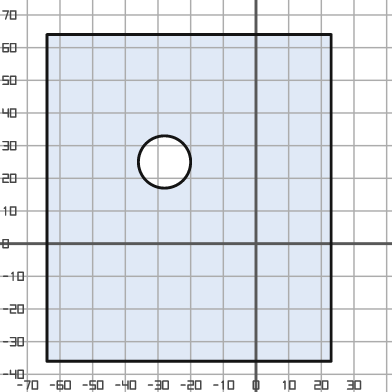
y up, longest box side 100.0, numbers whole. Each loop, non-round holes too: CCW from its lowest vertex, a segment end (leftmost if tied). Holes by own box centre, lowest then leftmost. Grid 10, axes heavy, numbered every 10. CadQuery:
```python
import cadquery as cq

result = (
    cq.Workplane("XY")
    .moveTo(-64.0, -36.0)
    .lineTo(23.0, -36.0)
    .lineTo(23.0, 64.0)
    .lineTo(-64.0, 64.0)
    .close()
    .moveTo(-28.0, 25.0)
    .circle(8.0)
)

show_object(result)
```